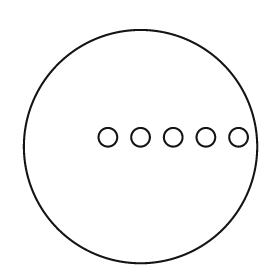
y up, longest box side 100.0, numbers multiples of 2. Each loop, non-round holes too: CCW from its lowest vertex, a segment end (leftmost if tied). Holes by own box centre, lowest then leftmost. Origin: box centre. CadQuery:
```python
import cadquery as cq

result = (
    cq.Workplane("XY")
    .moveTo(0.0, 0.0)
    .circle(50.0)
    .moveTo(-14.0, 4.0)
    .circle(4.0)
    .moveTo(0.0, 4.0)
    .circle(4.0)
    .moveTo(14.0, 4.0)
    .circle(4.0)
    .moveTo(28.0, 4.0)
    .circle(4.0)
    .moveTo(42.0, 4.0)
    .circle(4.0)
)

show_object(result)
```